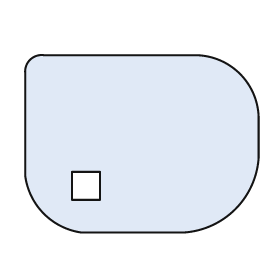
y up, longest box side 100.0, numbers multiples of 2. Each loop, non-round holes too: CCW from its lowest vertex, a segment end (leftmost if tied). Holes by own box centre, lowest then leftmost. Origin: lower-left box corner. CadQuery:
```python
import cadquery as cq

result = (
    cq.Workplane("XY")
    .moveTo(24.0, 0.0)
    .lineTo(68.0, 0.0)
    .threePointArc((90.0, 10.0), (100.0, 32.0))
    .lineTo(100.0, 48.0)
    .threePointArc((92.0, 68.0), (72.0, 76.0))
    .lineTo(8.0, 76.0)
    .threePointArc((2.0, 74.0), (0.0, 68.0))
    .lineTo(0.0, 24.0)
    .threePointArc((8.0, 8.0), (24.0, 0.0))
    .close()
    .moveTo(20.0, 14.0)
    .lineTo(32.0, 14.0)
    .lineTo(32.0, 26.0)
    .lineTo(20.0, 26.0)
    .close()
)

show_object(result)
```